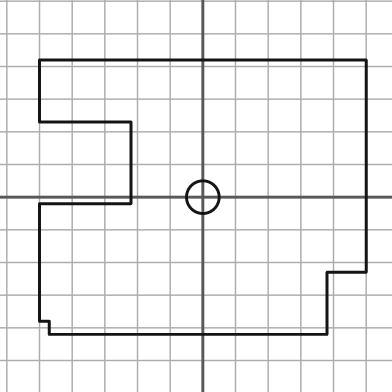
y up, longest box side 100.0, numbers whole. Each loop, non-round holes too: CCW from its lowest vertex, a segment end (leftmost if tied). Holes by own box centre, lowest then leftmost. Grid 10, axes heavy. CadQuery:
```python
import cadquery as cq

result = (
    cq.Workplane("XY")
    .moveTo(-47.0, -42.0)
    .lineTo(38.0, -42.0)
    .lineTo(38.0, -23.0)
    .lineTo(50.0, -23.0)
    .lineTo(50.0, 42.0)
    .lineTo(-50.0, 42.0)
    .lineTo(-50.0, 23.0)
    .lineTo(-22.0, 23.0)
    .lineTo(-22.0, -2.0)
    .lineTo(-50.0, -2.0)
    .lineTo(-50.0, -38.0)
    .lineTo(-47.0, -38.0)
    .close()
    .moveTo(0.0, 0.0)
    .circle(5.0)
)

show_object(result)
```